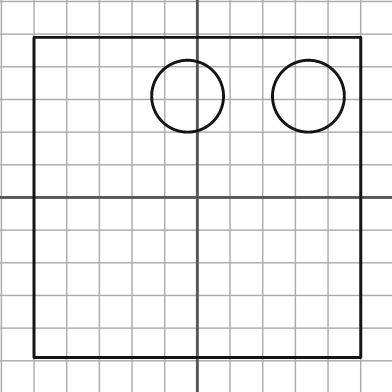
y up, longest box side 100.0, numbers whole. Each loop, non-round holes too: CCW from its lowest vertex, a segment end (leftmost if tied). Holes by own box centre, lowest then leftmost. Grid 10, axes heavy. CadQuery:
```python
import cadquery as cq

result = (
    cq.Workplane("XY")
    .moveTo(-50.0, -49.0)
    .lineTo(50.0, -49.0)
    .lineTo(50.0, 49.0)
    .lineTo(-50.0, 49.0)
    .close()
    .moveTo(-3.0, 31.0)
    .circle(11.0)
    .moveTo(34.0, 31.0)
    .circle(11.0)
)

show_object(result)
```